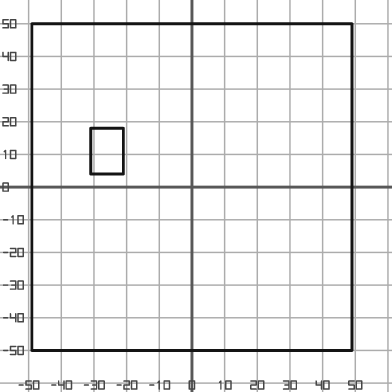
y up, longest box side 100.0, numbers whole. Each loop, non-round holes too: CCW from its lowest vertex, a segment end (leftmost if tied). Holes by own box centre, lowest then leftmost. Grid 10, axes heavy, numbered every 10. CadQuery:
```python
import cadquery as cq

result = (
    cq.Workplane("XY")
    .moveTo(-49.0, -50.0)
    .lineTo(49.0, -50.0)
    .lineTo(49.0, 50.0)
    .lineTo(-49.0, 50.0)
    .close()
    .moveTo(-31.0, 4.0)
    .lineTo(-21.0, 4.0)
    .lineTo(-21.0, 18.0)
    .lineTo(-31.0, 18.0)
    .close()
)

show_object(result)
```